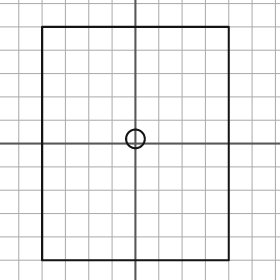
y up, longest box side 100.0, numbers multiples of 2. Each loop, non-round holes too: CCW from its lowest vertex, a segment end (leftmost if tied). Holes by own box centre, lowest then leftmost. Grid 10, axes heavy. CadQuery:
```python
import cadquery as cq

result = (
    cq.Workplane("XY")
    .moveTo(-40.0, -50.0)
    .lineTo(40.0, -50.0)
    .lineTo(40.0, 50.0)
    .lineTo(-40.0, 50.0)
    .close()
    .moveTo(0.0, 2.0)
    .circle(4.0)
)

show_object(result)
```